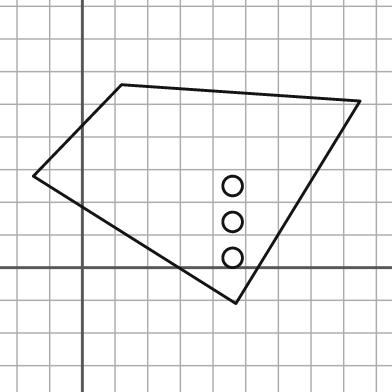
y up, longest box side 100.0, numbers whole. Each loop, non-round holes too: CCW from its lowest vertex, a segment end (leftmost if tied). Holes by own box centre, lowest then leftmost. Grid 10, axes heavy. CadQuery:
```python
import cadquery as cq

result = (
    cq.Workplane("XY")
    .moveTo(47.0, -11.0)
    .lineTo(85.0, 51.0)
    .lineTo(12.0, 56.0)
    .lineTo(-15.0, 28.0)
    .close()
    .moveTo(46.0, 3.0)
    .circle(3.0)
    .moveTo(46.0, 14.0)
    .circle(3.0)
    .moveTo(46.0, 25.0)
    .circle(3.0)
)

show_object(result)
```